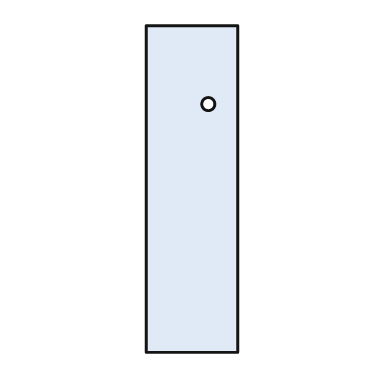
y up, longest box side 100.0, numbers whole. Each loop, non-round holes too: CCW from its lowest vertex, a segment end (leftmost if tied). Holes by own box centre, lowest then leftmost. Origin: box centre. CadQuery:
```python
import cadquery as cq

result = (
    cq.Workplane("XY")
    .moveTo(-14.0, -50.0)
    .lineTo(14.0, -50.0)
    .lineTo(14.0, 50.0)
    .lineTo(-14.0, 50.0)
    .close()
    .moveTo(5.0, 26.0)
    .circle(2.0)
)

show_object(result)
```